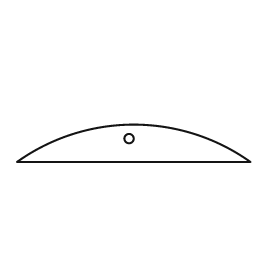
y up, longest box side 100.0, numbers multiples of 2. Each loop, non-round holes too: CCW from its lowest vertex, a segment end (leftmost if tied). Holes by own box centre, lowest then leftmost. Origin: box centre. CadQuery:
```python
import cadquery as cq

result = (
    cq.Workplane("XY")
    .moveTo(-50.0, -8.0)
    .lineTo(50.0, -8.0)
    .threePointArc((0.0, 8.0), (-50.0, -8.0))
    .close()
    .moveTo(-2.0, 2.0)
    .circle(2.0)
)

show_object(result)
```